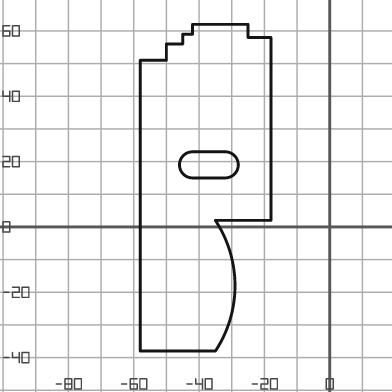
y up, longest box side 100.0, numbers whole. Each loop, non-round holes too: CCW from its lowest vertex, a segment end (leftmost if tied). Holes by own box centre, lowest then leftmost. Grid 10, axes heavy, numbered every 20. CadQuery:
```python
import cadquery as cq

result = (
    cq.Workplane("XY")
    .moveTo(-58.0, -38.0)
    .lineTo(-35.0, -38.0)
    .threePointArc((-29.0, -18.0), (-35.0, 2.0))
    .lineTo(-18.0, 2.0)
    .lineTo(-18.0, 58.0)
    .lineTo(-25.0, 58.0)
    .lineTo(-25.0, 62.0)
    .lineTo(-42.0, 62.0)
    .lineTo(-42.0, 59.0)
    .lineTo(-45.0, 59.0)
    .lineTo(-45.0, 56.0)
    .lineTo(-50.0, 56.0)
    .lineTo(-50.0, 51.0)
    .lineTo(-58.0, 51.0)
    .close()
    .moveTo(-42.0, 15.0)
    .lineTo(-32.0, 15.0)
    .threePointArc((-28.0, 19.0), (-32.0, 23.0))
    .lineTo(-42.0, 23.0)
    .threePointArc((-46.0, 19.0), (-42.0, 15.0))
    .close()
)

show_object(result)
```